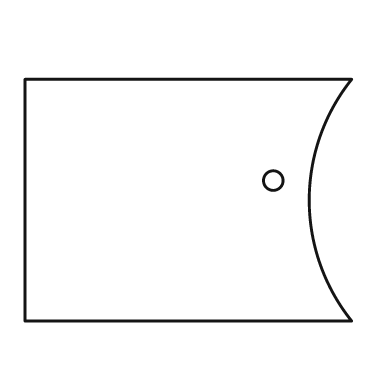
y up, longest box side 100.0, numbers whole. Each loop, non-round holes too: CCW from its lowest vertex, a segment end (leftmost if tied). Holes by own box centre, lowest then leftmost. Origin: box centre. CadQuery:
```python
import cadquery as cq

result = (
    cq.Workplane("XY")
    .moveTo(-50.0, -37.0)
    .lineTo(50.0, -37.0)
    .threePointArc((37.0, 0.0), (50.0, 37.0))
    .lineTo(-50.0, 37.0)
    .close()
    .moveTo(26.0, 6.0)
    .circle(3.0)
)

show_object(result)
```